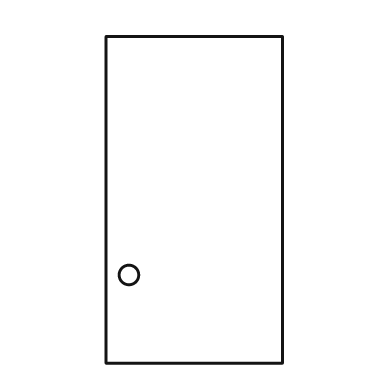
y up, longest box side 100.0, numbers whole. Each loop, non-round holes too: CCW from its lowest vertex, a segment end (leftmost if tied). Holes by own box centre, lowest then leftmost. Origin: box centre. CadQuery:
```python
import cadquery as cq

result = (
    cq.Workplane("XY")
    .moveTo(-27.0, -50.0)
    .lineTo(27.0, -50.0)
    .lineTo(27.0, 50.0)
    .lineTo(-27.0, 50.0)
    .close()
    .moveTo(-20.0, -23.0)
    .circle(3.0)
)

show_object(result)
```